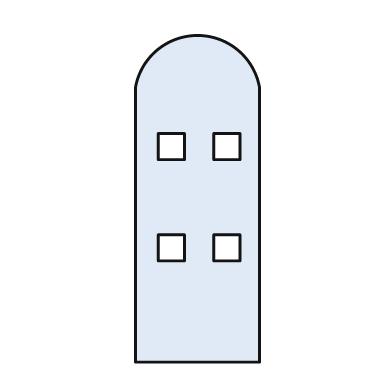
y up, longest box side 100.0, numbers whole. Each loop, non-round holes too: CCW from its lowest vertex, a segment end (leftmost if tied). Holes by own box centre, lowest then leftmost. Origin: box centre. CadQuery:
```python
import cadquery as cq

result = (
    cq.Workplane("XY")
    .moveTo(-19.0, -50.0)
    .lineTo(19.0, -50.0)
    .lineTo(19.0, 34.0)
    .threePointArc((0.0, 50.0), (-19.0, 34.0))
    .close()
    .moveTo(-12.0, -19.0)
    .lineTo(-4.0, -19.0)
    .lineTo(-4.0, -11.0)
    .lineTo(-12.0, -11.0)
    .close()
    .moveTo(5.0, -19.0)
    .lineTo(13.0, -19.0)
    .lineTo(13.0, -11.0)
    .lineTo(5.0, -11.0)
    .close()
    .moveTo(-12.0, 12.0)
    .lineTo(-4.0, 12.0)
    .lineTo(-4.0, 20.0)
    .lineTo(-12.0, 20.0)
    .close()
    .moveTo(5.0, 12.0)
    .lineTo(13.0, 12.0)
    .lineTo(13.0, 20.0)
    .lineTo(5.0, 20.0)
    .close()
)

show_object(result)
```